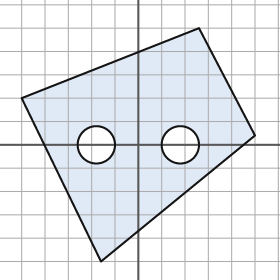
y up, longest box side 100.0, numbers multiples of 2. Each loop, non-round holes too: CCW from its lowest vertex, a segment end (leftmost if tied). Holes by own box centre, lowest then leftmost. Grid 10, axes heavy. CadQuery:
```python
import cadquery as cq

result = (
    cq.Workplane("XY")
    .moveTo(-16.0, -50.0)
    .lineTo(50.0, 4.0)
    .lineTo(26.0, 50.0)
    .lineTo(-50.0, 20.0)
    .close()
    .moveTo(-18.0, 0.0)
    .circle(8.0)
    .moveTo(18.0, 0.0)
    .circle(8.0)
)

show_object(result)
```